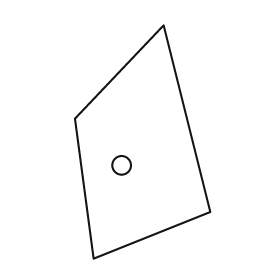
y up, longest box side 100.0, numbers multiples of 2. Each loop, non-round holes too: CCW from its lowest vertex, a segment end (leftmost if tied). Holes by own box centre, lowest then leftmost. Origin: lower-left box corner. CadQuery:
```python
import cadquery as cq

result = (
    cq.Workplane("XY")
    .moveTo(8.0, 0.0)
    .lineTo(58.0, 20.0)
    .lineTo(38.0, 100.0)
    .lineTo(0.0, 60.0)
    .close()
    .moveTo(20.0, 40.0)
    .circle(4.0)
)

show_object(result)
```